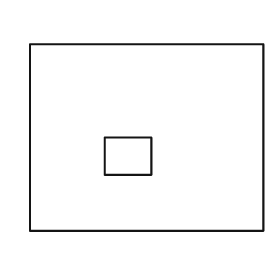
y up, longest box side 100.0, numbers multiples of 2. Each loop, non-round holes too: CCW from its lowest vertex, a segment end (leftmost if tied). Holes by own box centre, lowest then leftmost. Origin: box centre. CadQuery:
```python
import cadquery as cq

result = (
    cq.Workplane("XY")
    .moveTo(-50.0, -40.0)
    .lineTo(50.0, -40.0)
    .lineTo(50.0, 40.0)
    .lineTo(-50.0, 40.0)
    .close()
    .moveTo(-18.0, -16.0)
    .lineTo(2.0, -16.0)
    .lineTo(2.0, 0.0)
    .lineTo(-18.0, 0.0)
    .close()
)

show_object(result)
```